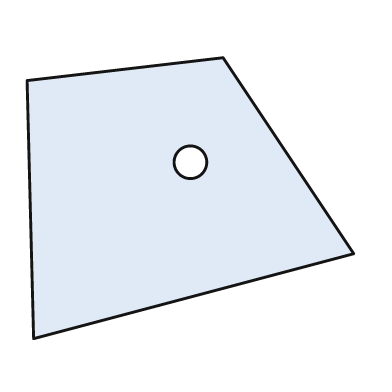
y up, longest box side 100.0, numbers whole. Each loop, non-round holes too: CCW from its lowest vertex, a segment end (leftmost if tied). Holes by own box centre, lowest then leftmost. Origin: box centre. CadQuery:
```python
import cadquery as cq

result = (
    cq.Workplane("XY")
    .moveTo(-48.0, -43.0)
    .lineTo(50.0, -17.0)
    .lineTo(10.0, 43.0)
    .lineTo(-50.0, 36.0)
    .close()
    .moveTo(0.0, 11.0)
    .circle(5.0)
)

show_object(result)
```